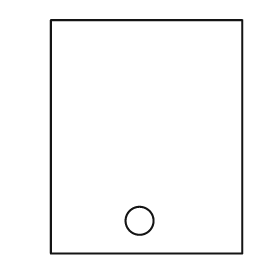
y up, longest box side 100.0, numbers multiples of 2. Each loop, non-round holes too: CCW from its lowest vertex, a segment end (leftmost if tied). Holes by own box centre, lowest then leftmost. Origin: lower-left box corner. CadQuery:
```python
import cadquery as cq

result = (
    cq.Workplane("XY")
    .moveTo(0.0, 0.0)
    .lineTo(82.0, 0.0)
    .lineTo(82.0, 100.0)
    .lineTo(0.0, 100.0)
    .close()
    .moveTo(38.0, 14.0)
    .circle(6.0)
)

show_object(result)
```